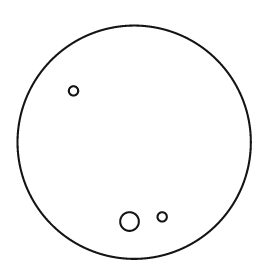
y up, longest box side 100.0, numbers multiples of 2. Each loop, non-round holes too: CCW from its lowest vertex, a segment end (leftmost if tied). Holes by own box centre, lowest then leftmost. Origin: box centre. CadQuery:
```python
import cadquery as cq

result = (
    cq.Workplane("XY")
    .moveTo(0.0, 0.0)
    .circle(50.0)
    .moveTo(-2.0, -34.0)
    .circle(4.0)
    .moveTo(12.0, -32.0)
    .circle(2.0)
    .moveTo(-26.0, 22.0)
    .circle(2.0)
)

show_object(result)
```